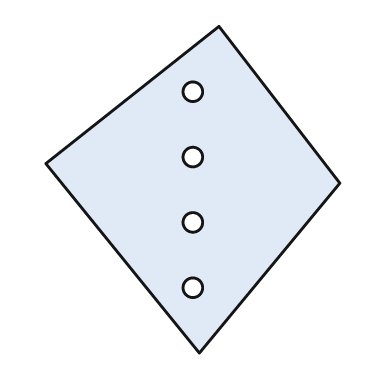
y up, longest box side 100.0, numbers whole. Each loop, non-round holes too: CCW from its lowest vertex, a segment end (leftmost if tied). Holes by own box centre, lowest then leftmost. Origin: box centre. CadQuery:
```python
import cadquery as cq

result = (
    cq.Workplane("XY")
    .moveTo(2.0, -50.0)
    .lineTo(45.0, 2.0)
    .lineTo(8.0, 50.0)
    .lineTo(-45.0, 8.0)
    .close()
    .moveTo(0.0, -30.0)
    .circle(3.0)
    .moveTo(0.0, -10.0)
    .circle(3.0)
    .moveTo(0.0, 10.0)
    .circle(3.0)
    .moveTo(0.0, 30.0)
    .circle(3.0)
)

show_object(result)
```